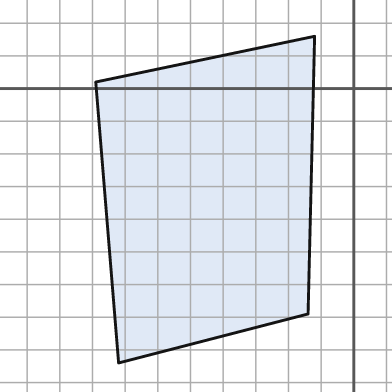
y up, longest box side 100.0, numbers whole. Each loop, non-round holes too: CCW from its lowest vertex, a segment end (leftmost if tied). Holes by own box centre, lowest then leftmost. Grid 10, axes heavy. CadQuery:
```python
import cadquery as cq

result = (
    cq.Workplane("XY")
    .moveTo(-72.0, -84.0)
    .lineTo(-14.0, -69.0)
    .lineTo(-12.0, 16.0)
    .lineTo(-79.0, 2.0)
    .close()
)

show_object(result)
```